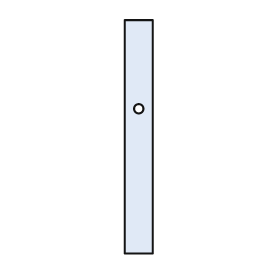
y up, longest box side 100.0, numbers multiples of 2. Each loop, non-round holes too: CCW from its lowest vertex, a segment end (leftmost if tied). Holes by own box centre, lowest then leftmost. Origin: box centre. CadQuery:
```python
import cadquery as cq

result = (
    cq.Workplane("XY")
    .moveTo(-6.0, -50.0)
    .lineTo(6.0, -50.0)
    .lineTo(6.0, 50.0)
    .lineTo(-6.0, 50.0)
    .close()
    .moveTo(0.0, 12.0)
    .circle(2.0)
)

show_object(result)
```